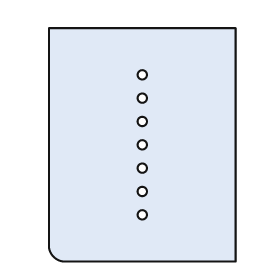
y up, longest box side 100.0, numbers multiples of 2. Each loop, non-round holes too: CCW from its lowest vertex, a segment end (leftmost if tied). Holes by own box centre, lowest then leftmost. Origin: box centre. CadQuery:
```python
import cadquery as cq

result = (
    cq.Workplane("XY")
    .moveTo(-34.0, -50.0)
    .lineTo(40.0, -50.0)
    .lineTo(40.0, 50.0)
    .lineTo(-40.0, 50.0)
    .lineTo(-40.0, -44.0)
    .threePointArc((-38.0, -48.0), (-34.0, -50.0))
    .close()
    .moveTo(0.0, -30.0)
    .circle(2.0)
    .moveTo(0.0, -20.0)
    .circle(2.0)
    .moveTo(0.0, -10.0)
    .circle(2.0)
    .moveTo(0.0, 0.0)
    .circle(2.0)
    .moveTo(0.0, 10.0)
    .circle(2.0)
    .moveTo(0.0, 20.0)
    .circle(2.0)
    .moveTo(0.0, 30.0)
    .circle(2.0)
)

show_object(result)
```